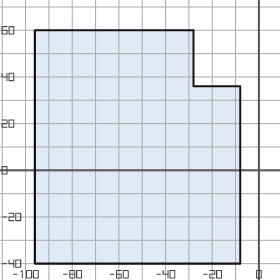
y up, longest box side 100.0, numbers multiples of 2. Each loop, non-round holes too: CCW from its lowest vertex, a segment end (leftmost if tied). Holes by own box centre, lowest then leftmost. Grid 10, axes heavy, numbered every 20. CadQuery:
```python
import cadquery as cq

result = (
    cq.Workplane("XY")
    .moveTo(-96.0, -40.0)
    .lineTo(-8.0, -40.0)
    .lineTo(-8.0, 36.0)
    .lineTo(-28.0, 36.0)
    .lineTo(-28.0, 60.0)
    .lineTo(-96.0, 60.0)
    .close()
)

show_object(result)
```